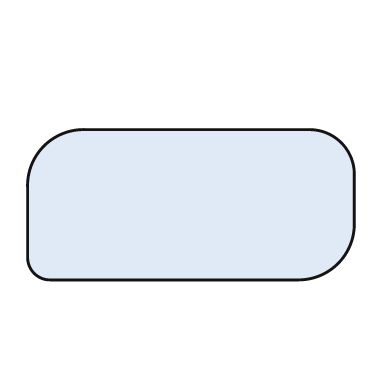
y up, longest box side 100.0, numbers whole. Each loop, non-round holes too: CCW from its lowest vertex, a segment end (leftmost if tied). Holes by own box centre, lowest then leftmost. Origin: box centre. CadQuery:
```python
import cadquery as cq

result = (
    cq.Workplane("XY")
    .moveTo(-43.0, -23.0)
    .lineTo(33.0, -23.0)
    .threePointArc((45.0, -18.0), (50.0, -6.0))
    .lineTo(50.0, 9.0)
    .threePointArc((46.0, 19.0), (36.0, 23.0))
    .lineTo(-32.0, 23.0)
    .threePointArc((-45.0, 18.0), (-50.0, 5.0))
    .lineTo(-50.0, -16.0)
    .threePointArc((-48.0, -21.0), (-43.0, -23.0))
    .close()
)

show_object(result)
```